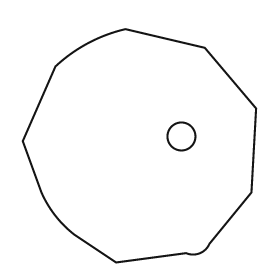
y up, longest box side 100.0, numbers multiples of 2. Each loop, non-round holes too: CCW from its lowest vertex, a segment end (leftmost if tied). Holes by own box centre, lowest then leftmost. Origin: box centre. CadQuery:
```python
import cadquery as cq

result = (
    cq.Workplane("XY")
    .moveTo(-10.0, -50.0)
    .lineTo(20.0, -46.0)
    .threePointArc((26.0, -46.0), (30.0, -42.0))
    .lineTo(48.0, -20.0)
    .lineTo(50.0, 16.0)
    .lineTo(28.0, 42.0)
    .lineTo(-6.0, 50.0)
    .threePointArc((-22.0, 44.0), (-36.0, 34.0))
    .lineTo(-50.0, 2.0)
    .lineTo(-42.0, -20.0)
    .threePointArc((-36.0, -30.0), (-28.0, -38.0))
    .close()
    .moveTo(18.0, 4.0)
    .circle(6.0)
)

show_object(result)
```